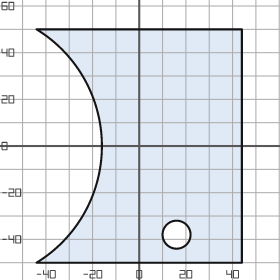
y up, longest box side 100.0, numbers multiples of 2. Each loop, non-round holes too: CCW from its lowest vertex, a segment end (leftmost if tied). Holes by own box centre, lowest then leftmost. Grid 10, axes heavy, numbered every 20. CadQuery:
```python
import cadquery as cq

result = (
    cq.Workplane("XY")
    .moveTo(-44.0, -50.0)
    .lineTo(44.0, -50.0)
    .lineTo(44.0, 50.0)
    .lineTo(-44.0, 50.0)
    .threePointArc((-16.0, 0.0), (-44.0, -50.0))
    .close()
    .moveTo(16.0, -38.0)
    .circle(6.0)
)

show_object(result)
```